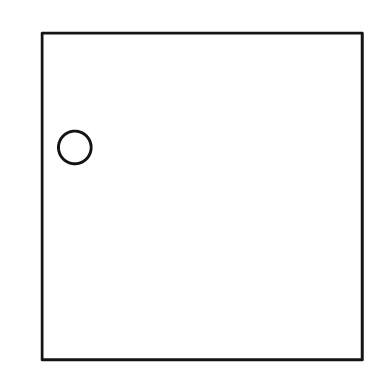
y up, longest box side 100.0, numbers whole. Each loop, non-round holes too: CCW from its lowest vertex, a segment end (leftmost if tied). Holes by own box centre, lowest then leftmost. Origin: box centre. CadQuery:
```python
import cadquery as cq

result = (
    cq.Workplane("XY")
    .moveTo(-49.0, -50.0)
    .lineTo(49.0, -50.0)
    .lineTo(49.0, 50.0)
    .lineTo(-49.0, 50.0)
    .close()
    .moveTo(-39.0, 15.0)
    .circle(5.0)
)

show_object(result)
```